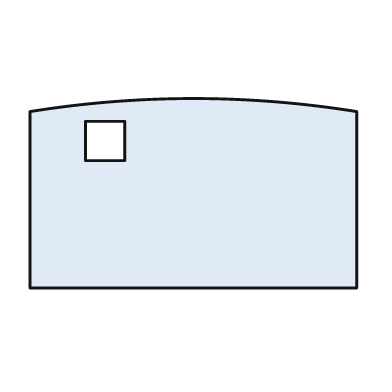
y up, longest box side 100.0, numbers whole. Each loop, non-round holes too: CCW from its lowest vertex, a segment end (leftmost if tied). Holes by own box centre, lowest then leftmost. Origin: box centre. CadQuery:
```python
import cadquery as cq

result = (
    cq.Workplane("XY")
    .moveTo(-50.0, -29.0)
    .lineTo(50.0, -29.0)
    .lineTo(50.0, 25.0)
    .threePointArc((0.0, 29.0), (-50.0, 25.0))
    .close()
    .moveTo(-33.0, 10.0)
    .lineTo(-21.0, 10.0)
    .lineTo(-21.0, 22.0)
    .lineTo(-33.0, 22.0)
    .close()
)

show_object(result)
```